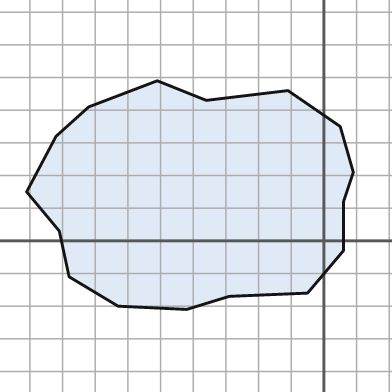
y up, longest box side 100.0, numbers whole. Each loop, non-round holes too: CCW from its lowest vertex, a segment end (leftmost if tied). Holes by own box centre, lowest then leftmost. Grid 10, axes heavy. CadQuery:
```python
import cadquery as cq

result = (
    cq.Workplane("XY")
    .moveTo(-42.0, -21.0)
    .lineTo(-29.0, -17.0)
    .lineTo(-5.0, -16.0)
    .lineTo(6.0, -3.0)
    .lineTo(6.0, 12.0)
    .lineTo(9.0, 21.0)
    .lineTo(5.0, 35.0)
    .lineTo(-11.0, 46.0)
    .lineTo(-36.0, 43.0)
    .lineTo(-51.0, 49.0)
    .lineTo(-72.0, 41.0)
    .lineTo(-82.0, 32.0)
    .lineTo(-91.0, 15.0)
    .lineTo(-81.0, 3.0)
    .lineTo(-78.0, -11.0)
    .lineTo(-63.0, -20.0)
    .close()
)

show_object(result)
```